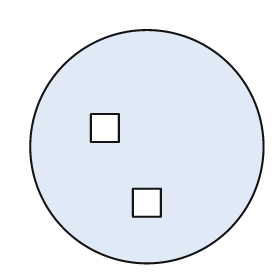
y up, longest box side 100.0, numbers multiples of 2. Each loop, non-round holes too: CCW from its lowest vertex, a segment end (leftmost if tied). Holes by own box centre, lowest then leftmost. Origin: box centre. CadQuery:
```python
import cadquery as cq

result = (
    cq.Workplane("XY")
    .moveTo(0.0, 0.0)
    .circle(50.0)
    .moveTo(-6.0, -30.0)
    .lineTo(6.0, -30.0)
    .lineTo(6.0, -18.0)
    .lineTo(-6.0, -18.0)
    .close()
    .moveTo(-24.0, 2.0)
    .lineTo(-12.0, 2.0)
    .lineTo(-12.0, 14.0)
    .lineTo(-24.0, 14.0)
    .close()
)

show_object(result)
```